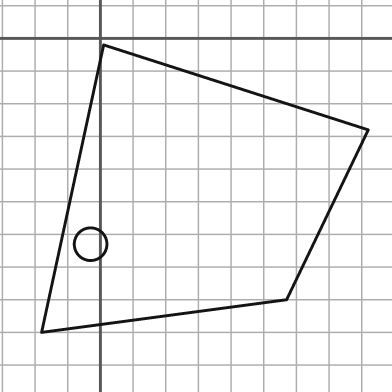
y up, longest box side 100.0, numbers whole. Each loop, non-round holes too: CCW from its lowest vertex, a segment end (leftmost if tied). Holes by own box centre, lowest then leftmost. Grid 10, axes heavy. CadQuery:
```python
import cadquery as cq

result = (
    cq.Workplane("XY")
    .moveTo(-18.0, -90.0)
    .lineTo(57.0, -80.0)
    .lineTo(82.0, -28.0)
    .lineTo(1.0, -2.0)
    .close()
    .moveTo(-3.0, -63.0)
    .circle(5.0)
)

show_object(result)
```